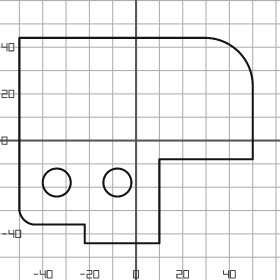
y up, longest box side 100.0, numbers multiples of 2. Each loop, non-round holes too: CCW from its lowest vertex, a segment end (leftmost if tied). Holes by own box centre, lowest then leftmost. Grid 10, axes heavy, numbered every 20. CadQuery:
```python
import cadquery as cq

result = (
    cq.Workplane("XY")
    .moveTo(-22.0, -44.0)
    .lineTo(10.0, -44.0)
    .lineTo(10.0, -8.0)
    .lineTo(50.0, -8.0)
    .lineTo(50.0, 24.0)
    .threePointArc((44.0, 38.0), (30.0, 44.0))
    .lineTo(-50.0, 44.0)
    .lineTo(-50.0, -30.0)
    .threePointArc((-48.0, -34.0), (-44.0, -36.0))
    .lineTo(-22.0, -36.0)
    .close()
    .moveTo(-34.0, -18.0)
    .circle(6.0)
    .moveTo(-8.0, -18.0)
    .circle(6.0)
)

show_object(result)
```